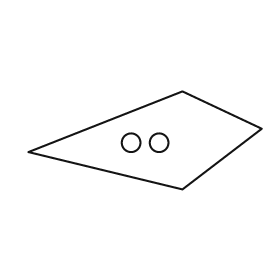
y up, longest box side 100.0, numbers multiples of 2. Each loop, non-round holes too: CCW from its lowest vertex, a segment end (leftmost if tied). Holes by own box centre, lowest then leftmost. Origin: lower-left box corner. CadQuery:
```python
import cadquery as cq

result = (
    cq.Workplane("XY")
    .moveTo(66.0, 0.0)
    .lineTo(100.0, 26.0)
    .lineTo(66.0, 42.0)
    .lineTo(0.0, 16.0)
    .close()
    .moveTo(44.0, 20.0)
    .circle(4.0)
    .moveTo(56.0, 20.0)
    .circle(4.0)
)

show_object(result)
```